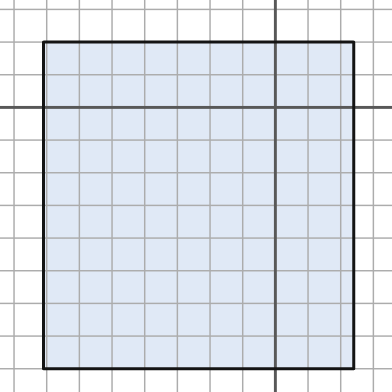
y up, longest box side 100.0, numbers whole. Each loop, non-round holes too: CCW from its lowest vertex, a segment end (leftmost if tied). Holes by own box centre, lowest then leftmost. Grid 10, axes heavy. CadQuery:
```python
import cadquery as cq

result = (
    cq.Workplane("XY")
    .moveTo(-71.0, -80.0)
    .lineTo(24.0, -80.0)
    .lineTo(24.0, 20.0)
    .lineTo(-71.0, 20.0)
    .close()
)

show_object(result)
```